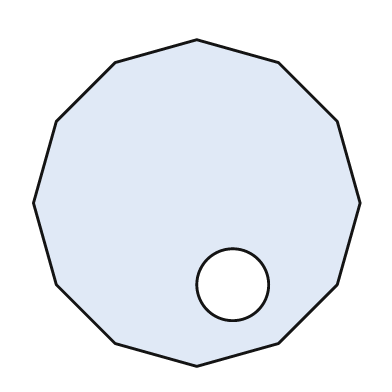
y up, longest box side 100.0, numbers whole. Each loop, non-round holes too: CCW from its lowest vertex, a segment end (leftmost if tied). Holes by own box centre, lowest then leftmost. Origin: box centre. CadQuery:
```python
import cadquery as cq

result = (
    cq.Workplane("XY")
    .moveTo(0.0, -50.0)
    .lineTo(25.0, -43.0)
    .lineTo(43.0, -25.0)
    .lineTo(50.0, 0.0)
    .lineTo(43.0, 25.0)
    .lineTo(25.0, 43.0)
    .lineTo(0.0, 50.0)
    .lineTo(-25.0, 43.0)
    .lineTo(-43.0, 25.0)
    .lineTo(-50.0, 0.0)
    .lineTo(-43.0, -25.0)
    .lineTo(-25.0, -43.0)
    .close()
    .moveTo(11.0, -25.0)
    .circle(11.0)
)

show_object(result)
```